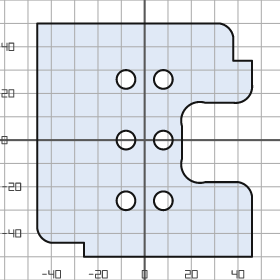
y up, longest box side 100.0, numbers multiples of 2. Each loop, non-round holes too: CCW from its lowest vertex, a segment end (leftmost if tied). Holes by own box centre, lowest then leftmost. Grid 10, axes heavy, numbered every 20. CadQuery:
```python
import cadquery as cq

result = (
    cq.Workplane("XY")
    .moveTo(-26.0, -50.0)
    .lineTo(46.0, -50.0)
    .lineTo(46.0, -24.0)
    .threePointArc((44.0, -20.0), (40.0, -18.0))
    .lineTo(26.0, -18.0)
    .threePointArc((18.0, -16.0), (16.0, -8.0))
    .lineTo(16.0, 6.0)
    .threePointArc((18.0, 14.0), (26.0, 16.0))
    .lineTo(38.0, 16.0)
    .threePointArc((44.0, 18.0), (46.0, 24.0))
    .lineTo(46.0, 34.0)
    .lineTo(38.0, 34.0)
    .lineTo(38.0, 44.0)
    .threePointArc((36.0, 48.0), (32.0, 50.0))
    .lineTo(-46.0, 50.0)
    .lineTo(-46.0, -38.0)
    .threePointArc((-44.0, -42.0), (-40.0, -44.0))
    .lineTo(-26.0, -44.0)
    .close()
    .moveTo(-8.0, -26.0)
    .circle(4.0)
    .moveTo(8.0, -26.0)
    .circle(4.0)
    .moveTo(-8.0, 0.0)
    .circle(4.0)
    .moveTo(8.0, 0.0)
    .circle(4.0)
    .moveTo(-8.0, 26.0)
    .circle(4.0)
    .moveTo(8.0, 26.0)
    .circle(4.0)
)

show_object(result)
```